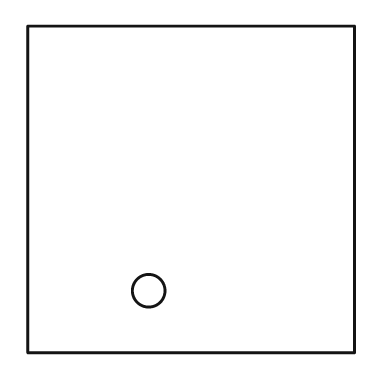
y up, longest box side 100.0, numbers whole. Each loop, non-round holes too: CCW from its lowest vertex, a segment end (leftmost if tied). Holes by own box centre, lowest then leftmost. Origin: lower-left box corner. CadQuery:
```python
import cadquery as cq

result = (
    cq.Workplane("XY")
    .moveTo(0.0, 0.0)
    .lineTo(100.0, 0.0)
    .lineTo(100.0, 100.0)
    .lineTo(0.0, 100.0)
    .close()
    .moveTo(37.0, 19.0)
    .circle(5.0)
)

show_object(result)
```